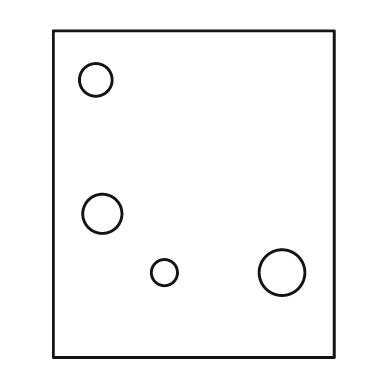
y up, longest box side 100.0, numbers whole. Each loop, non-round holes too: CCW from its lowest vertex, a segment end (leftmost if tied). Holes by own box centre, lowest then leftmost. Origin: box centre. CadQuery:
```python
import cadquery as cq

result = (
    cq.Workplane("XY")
    .moveTo(-43.0, -50.0)
    .lineTo(43.0, -50.0)
    .lineTo(43.0, 50.0)
    .lineTo(-43.0, 50.0)
    .close()
    .moveTo(-9.0, -24.0)
    .circle(4.0)
    .moveTo(27.0, -24.0)
    .circle(7.0)
    .moveTo(-28.0, -6.0)
    .circle(6.0)
    .moveTo(-30.0, 35.0)
    .circle(5.0)
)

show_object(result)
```